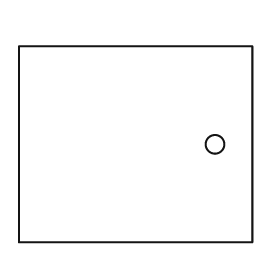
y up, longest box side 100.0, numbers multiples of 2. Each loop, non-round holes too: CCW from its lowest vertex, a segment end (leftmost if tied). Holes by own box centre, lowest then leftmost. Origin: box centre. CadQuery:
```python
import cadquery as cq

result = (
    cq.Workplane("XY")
    .moveTo(-50.0, -42.0)
    .lineTo(50.0, -42.0)
    .lineTo(50.0, 42.0)
    .lineTo(-50.0, 42.0)
    .close()
    .moveTo(34.0, 0.0)
    .circle(4.0)
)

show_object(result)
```